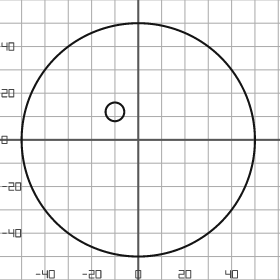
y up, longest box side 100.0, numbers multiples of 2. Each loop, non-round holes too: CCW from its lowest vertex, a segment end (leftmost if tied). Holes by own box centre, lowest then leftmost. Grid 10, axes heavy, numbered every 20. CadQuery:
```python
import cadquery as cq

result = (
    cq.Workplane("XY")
    .moveTo(0.0, 0.0)
    .circle(50.0)
    .moveTo(-10.0, 12.0)
    .circle(4.0)
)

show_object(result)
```